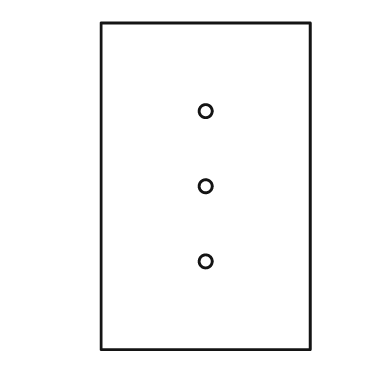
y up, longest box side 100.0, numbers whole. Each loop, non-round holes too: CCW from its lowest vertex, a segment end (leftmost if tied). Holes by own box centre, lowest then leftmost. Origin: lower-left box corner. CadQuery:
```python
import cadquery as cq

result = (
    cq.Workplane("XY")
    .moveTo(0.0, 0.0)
    .lineTo(64.0, 0.0)
    .lineTo(64.0, 100.0)
    .lineTo(0.0, 100.0)
    .close()
    .moveTo(32.0, 27.0)
    .circle(2.0)
    .moveTo(32.0, 50.0)
    .circle(2.0)
    .moveTo(32.0, 73.0)
    .circle(2.0)
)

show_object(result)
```